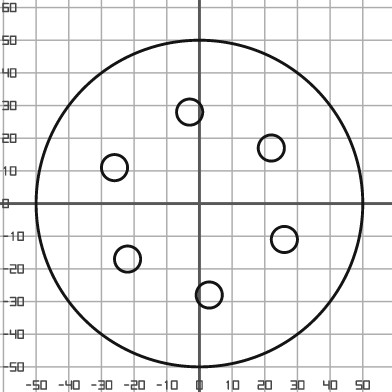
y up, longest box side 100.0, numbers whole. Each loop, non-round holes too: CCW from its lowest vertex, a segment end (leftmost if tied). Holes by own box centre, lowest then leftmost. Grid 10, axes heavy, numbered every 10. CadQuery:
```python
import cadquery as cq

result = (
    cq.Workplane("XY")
    .moveTo(0.0, 0.0)
    .circle(50.0)
    .moveTo(3.0, -28.0)
    .circle(4.0)
    .moveTo(-22.0, -17.0)
    .circle(4.0)
    .moveTo(26.0, -11.0)
    .circle(4.0)
    .moveTo(-26.0, 11.0)
    .circle(4.0)
    .moveTo(22.0, 17.0)
    .circle(4.0)
    .moveTo(-3.0, 28.0)
    .circle(4.0)
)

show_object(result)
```